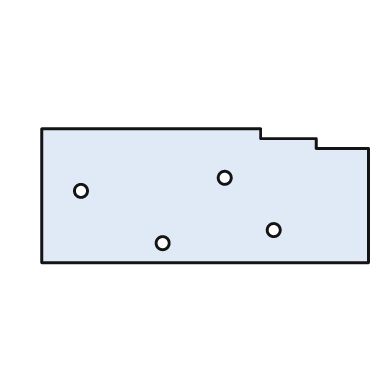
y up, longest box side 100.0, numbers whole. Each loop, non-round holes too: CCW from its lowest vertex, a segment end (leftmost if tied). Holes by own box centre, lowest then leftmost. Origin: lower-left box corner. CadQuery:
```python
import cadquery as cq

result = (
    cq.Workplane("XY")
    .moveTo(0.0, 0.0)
    .lineTo(100.0, 0.0)
    .lineTo(100.0, 35.0)
    .lineTo(84.0, 35.0)
    .lineTo(84.0, 38.0)
    .lineTo(67.0, 38.0)
    .lineTo(67.0, 41.0)
    .lineTo(0.0, 41.0)
    .close()
    .moveTo(37.0, 6.0)
    .circle(2.0)
    .moveTo(71.0, 10.0)
    .circle(2.0)
    .moveTo(12.0, 22.0)
    .circle(2.0)
    .moveTo(56.0, 26.0)
    .circle(2.0)
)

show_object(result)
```